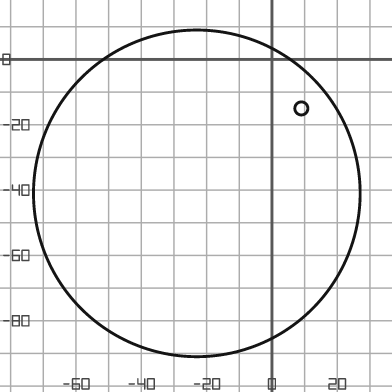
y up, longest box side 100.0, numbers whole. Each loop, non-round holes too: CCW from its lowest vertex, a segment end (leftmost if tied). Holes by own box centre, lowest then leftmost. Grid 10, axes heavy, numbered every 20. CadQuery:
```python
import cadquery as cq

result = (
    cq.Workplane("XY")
    .moveTo(-23.0, -41.0)
    .circle(50.0)
    .moveTo(9.0, -15.0)
    .circle(2.0)
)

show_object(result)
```